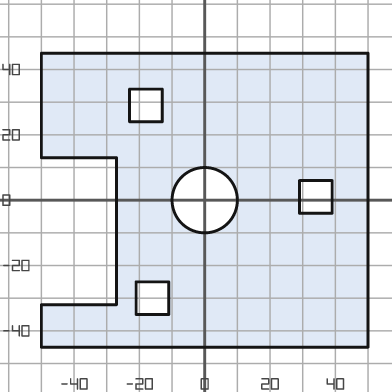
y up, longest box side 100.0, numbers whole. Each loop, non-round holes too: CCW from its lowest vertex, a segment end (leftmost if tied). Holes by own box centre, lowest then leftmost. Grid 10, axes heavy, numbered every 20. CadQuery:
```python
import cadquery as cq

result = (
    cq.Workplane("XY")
    .moveTo(-50.0, -45.0)
    .lineTo(50.0, -45.0)
    .lineTo(50.0, 45.0)
    .lineTo(-50.0, 45.0)
    .lineTo(-50.0, 13.0)
    .lineTo(-27.0, 13.0)
    .lineTo(-27.0, -32.0)
    .lineTo(-50.0, -32.0)
    .close()
    .moveTo(-21.0, -35.0)
    .lineTo(-11.0, -35.0)
    .lineTo(-11.0, -25.0)
    .lineTo(-21.0, -25.0)
    .close()
    .moveTo(0.0, 0.0)
    .circle(10.0)
    .moveTo(29.0, -4.0)
    .lineTo(39.0, -4.0)
    .lineTo(39.0, 6.0)
    .lineTo(29.0, 6.0)
    .close()
    .moveTo(-23.0, 24.0)
    .lineTo(-13.0, 24.0)
    .lineTo(-13.0, 34.0)
    .lineTo(-23.0, 34.0)
    .close()
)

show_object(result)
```